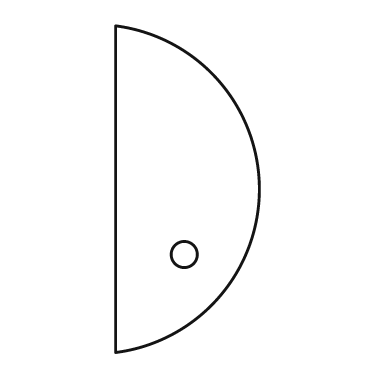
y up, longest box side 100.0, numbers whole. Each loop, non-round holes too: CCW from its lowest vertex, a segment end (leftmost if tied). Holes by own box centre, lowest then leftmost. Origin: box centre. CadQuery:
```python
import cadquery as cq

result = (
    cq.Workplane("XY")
    .moveTo(-22.0, -50.0)
    .threePointArc((22.0, 0.0), (-22.0, 50.0))
    .close()
    .moveTo(-1.0, -20.0)
    .circle(4.0)
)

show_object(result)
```